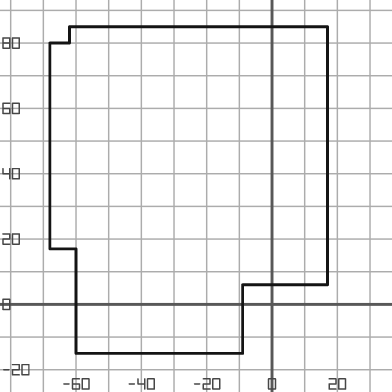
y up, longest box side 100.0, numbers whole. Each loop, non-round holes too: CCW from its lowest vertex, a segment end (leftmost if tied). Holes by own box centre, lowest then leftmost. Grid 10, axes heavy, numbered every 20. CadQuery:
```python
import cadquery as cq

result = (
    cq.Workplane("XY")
    .moveTo(-60.0, -15.0)
    .lineTo(-9.0, -15.0)
    .lineTo(-9.0, 6.0)
    .lineTo(17.0, 6.0)
    .lineTo(17.0, 85.0)
    .lineTo(-62.0, 85.0)
    .lineTo(-62.0, 80.0)
    .lineTo(-68.0, 80.0)
    .lineTo(-68.0, 17.0)
    .lineTo(-60.0, 17.0)
    .close()
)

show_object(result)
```